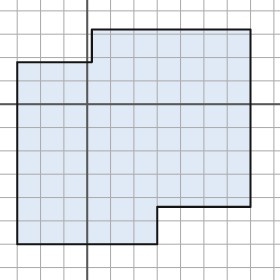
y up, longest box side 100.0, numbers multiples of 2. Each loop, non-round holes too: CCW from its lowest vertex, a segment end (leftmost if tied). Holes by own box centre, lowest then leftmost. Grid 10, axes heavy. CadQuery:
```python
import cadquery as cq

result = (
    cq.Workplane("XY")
    .moveTo(-30.0, -60.0)
    .lineTo(30.0, -60.0)
    .lineTo(30.0, -44.0)
    .lineTo(70.0, -44.0)
    .lineTo(70.0, 32.0)
    .lineTo(2.0, 32.0)
    .lineTo(2.0, 18.0)
    .lineTo(-30.0, 18.0)
    .close()
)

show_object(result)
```